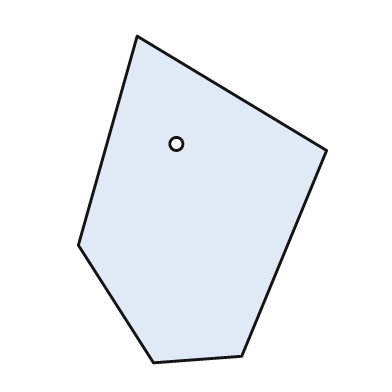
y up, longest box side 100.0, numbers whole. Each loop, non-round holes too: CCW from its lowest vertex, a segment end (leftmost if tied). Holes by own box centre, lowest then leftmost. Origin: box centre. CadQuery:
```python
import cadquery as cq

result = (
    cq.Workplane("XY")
    .moveTo(-15.0, -50.0)
    .lineTo(12.0, -48.0)
    .lineTo(38.0, 15.0)
    .lineTo(-20.0, 50.0)
    .lineTo(-38.0, -14.0)
    .close()
    .moveTo(-8.0, 17.0)
    .circle(2.0)
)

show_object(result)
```